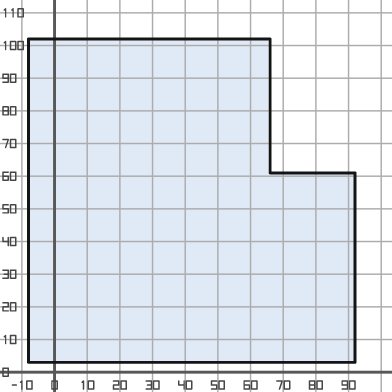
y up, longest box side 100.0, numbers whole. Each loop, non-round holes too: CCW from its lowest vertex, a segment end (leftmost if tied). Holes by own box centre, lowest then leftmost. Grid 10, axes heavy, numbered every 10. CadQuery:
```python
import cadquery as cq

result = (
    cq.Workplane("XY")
    .moveTo(-8.0, 3.0)
    .lineTo(92.0, 3.0)
    .lineTo(92.0, 61.0)
    .lineTo(66.0, 61.0)
    .lineTo(66.0, 102.0)
    .lineTo(-8.0, 102.0)
    .close()
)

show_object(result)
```